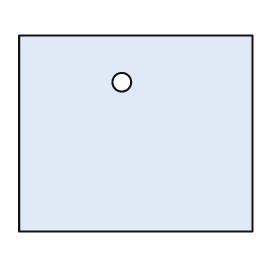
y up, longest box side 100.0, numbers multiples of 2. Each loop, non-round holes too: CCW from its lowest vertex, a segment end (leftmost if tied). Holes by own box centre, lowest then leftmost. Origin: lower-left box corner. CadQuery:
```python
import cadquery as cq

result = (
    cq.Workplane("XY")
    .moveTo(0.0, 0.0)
    .lineTo(100.0, 0.0)
    .lineTo(100.0, 84.0)
    .lineTo(0.0, 84.0)
    .close()
    .moveTo(44.0, 64.0)
    .circle(4.0)
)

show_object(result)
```